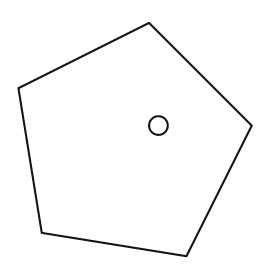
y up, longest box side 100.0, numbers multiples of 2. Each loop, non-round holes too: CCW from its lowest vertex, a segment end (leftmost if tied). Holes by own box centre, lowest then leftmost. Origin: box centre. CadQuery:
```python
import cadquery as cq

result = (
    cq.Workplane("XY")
    .moveTo(22.0, -50.0)
    .lineTo(50.0, 6.0)
    .lineTo(6.0, 50.0)
    .lineTo(-50.0, 22.0)
    .lineTo(-40.0, -40.0)
    .close()
    .moveTo(10.0, 6.0)
    .circle(4.0)
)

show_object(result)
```